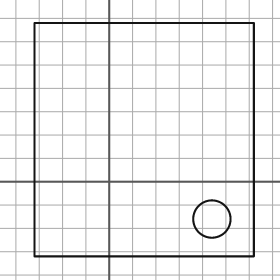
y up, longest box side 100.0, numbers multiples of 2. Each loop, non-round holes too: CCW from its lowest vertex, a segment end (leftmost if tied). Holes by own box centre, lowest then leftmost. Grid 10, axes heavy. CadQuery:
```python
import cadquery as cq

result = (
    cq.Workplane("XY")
    .moveTo(-32.0, -32.0)
    .lineTo(62.0, -32.0)
    .lineTo(62.0, 68.0)
    .lineTo(-32.0, 68.0)
    .close()
    .moveTo(44.0, -16.0)
    .circle(8.0)
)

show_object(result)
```